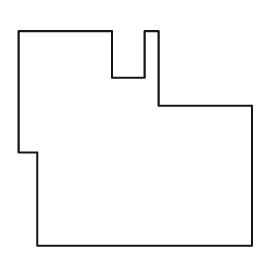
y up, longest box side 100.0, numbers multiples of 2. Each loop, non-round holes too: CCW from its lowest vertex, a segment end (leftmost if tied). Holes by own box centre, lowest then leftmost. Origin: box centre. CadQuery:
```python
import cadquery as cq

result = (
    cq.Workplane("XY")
    .moveTo(-42.0, -46.0)
    .lineTo(50.0, -46.0)
    .lineTo(50.0, 14.0)
    .lineTo(10.0, 14.0)
    .lineTo(10.0, 46.0)
    .lineTo(4.0, 46.0)
    .lineTo(4.0, 26.0)
    .lineTo(-10.0, 26.0)
    .lineTo(-10.0, 46.0)
    .lineTo(-50.0, 46.0)
    .lineTo(-50.0, -6.0)
    .lineTo(-42.0, -6.0)
    .close()
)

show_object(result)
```